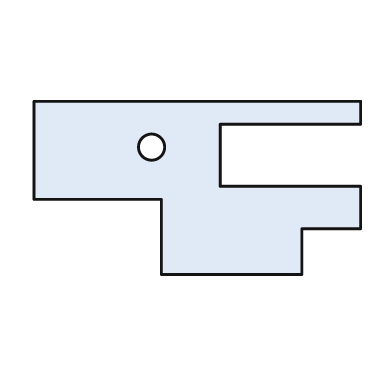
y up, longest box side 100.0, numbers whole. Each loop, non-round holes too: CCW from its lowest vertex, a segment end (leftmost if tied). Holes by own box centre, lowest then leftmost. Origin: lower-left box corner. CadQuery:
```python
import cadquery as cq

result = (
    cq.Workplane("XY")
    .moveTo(39.0, 0.0)
    .lineTo(82.0, 0.0)
    .lineTo(82.0, 14.0)
    .lineTo(100.0, 14.0)
    .lineTo(100.0, 27.0)
    .lineTo(57.0, 27.0)
    .lineTo(57.0, 46.0)
    .lineTo(100.0, 46.0)
    .lineTo(100.0, 53.0)
    .lineTo(0.0, 53.0)
    .lineTo(0.0, 23.0)
    .lineTo(39.0, 23.0)
    .close()
    .moveTo(36.0, 39.0)
    .circle(4.0)
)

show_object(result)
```